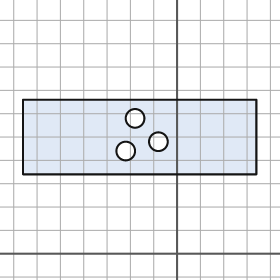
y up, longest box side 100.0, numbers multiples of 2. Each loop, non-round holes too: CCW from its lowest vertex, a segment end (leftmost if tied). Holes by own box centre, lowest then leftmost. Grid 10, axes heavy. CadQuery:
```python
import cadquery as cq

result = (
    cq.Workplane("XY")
    .moveTo(-66.0, 34.0)
    .lineTo(34.0, 34.0)
    .lineTo(34.0, 66.0)
    .lineTo(-66.0, 66.0)
    .close()
    .moveTo(-22.0, 44.0)
    .circle(4.0)
    .moveTo(-8.0, 48.0)
    .circle(4.0)
    .moveTo(-18.0, 58.0)
    .circle(4.0)
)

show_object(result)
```